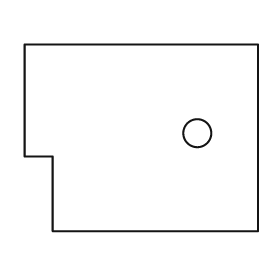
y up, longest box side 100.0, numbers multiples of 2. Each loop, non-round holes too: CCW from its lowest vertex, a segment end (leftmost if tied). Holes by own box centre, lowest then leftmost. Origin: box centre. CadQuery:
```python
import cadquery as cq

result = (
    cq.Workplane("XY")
    .moveTo(-38.0, -40.0)
    .lineTo(50.0, -40.0)
    .lineTo(50.0, 40.0)
    .lineTo(-50.0, 40.0)
    .lineTo(-50.0, -8.0)
    .lineTo(-38.0, -8.0)
    .close()
    .moveTo(24.0, 2.0)
    .circle(6.0)
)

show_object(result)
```